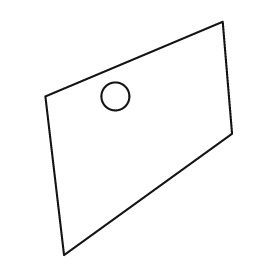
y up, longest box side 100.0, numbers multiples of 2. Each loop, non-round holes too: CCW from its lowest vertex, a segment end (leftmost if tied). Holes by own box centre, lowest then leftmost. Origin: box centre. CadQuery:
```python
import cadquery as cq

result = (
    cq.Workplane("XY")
    .moveTo(-32.0, -50.0)
    .lineTo(40.0, 2.0)
    .lineTo(36.0, 50.0)
    .lineTo(-40.0, 18.0)
    .close()
    .moveTo(-10.0, 18.0)
    .circle(6.0)
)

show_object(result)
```